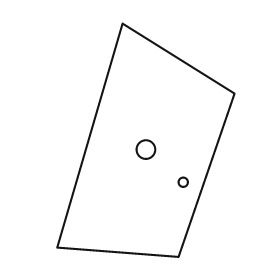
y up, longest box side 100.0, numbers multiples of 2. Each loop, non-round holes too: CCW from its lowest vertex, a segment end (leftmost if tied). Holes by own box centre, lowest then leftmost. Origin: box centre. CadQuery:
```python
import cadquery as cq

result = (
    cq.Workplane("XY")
    .moveTo(14.0, -50.0)
    .lineTo(38.0, 20.0)
    .lineTo(-10.0, 50.0)
    .lineTo(-38.0, -46.0)
    .close()
    .moveTo(16.0, -18.0)
    .circle(2.0)
    .moveTo(0.0, -4.0)
    .circle(4.0)
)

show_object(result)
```